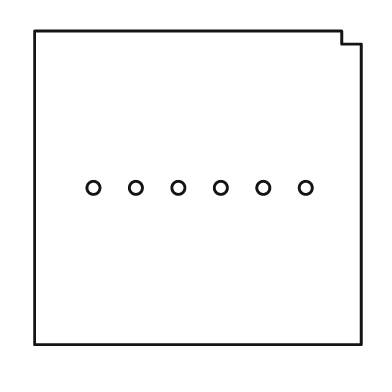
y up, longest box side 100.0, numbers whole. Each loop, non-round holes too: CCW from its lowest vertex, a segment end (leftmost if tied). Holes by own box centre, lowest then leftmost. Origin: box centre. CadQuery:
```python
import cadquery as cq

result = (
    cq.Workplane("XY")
    .moveTo(-50.0, -48.0)
    .lineTo(50.0, -48.0)
    .lineTo(50.0, 44.0)
    .lineTo(44.0, 44.0)
    .lineTo(44.0, 48.0)
    .lineTo(-50.0, 48.0)
    .close()
    .moveTo(-32.0, 0.0)
    .circle(2.0)
    .moveTo(-19.0, 0.0)
    .circle(2.0)
    .moveTo(-6.0, 0.0)
    .circle(2.0)
    .moveTo(7.0, 0.0)
    .circle(2.0)
    .moveTo(20.0, 0.0)
    .circle(2.0)
    .moveTo(33.0, 0.0)
    .circle(2.0)
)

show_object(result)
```